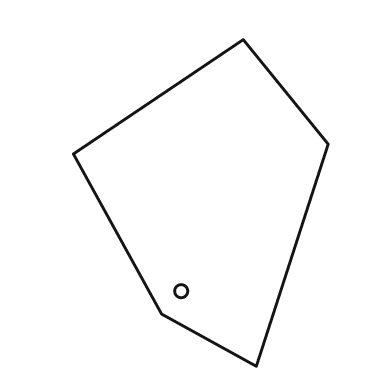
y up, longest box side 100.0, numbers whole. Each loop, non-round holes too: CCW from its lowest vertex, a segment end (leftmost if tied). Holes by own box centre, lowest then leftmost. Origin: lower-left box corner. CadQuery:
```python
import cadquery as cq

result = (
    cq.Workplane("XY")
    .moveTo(56.0, 0.0)
    .lineTo(78.0, 68.0)
    .lineTo(52.0, 100.0)
    .lineTo(0.0, 65.0)
    .lineTo(27.0, 16.0)
    .close()
    .moveTo(33.0, 23.0)
    .circle(2.0)
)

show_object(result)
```